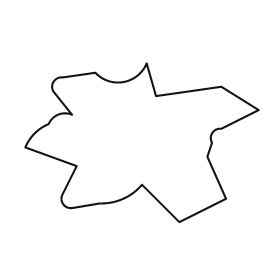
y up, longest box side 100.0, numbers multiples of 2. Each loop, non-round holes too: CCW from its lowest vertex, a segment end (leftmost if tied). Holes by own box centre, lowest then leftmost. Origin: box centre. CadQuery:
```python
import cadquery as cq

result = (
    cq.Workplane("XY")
    .moveTo(16.0, -34.0)
    .lineTo(36.0, -24.0)
    .lineTo(28.0, -6.0)
    .lineTo(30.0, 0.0)
    .threePointArc((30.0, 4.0), (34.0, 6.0))
    .lineTo(50.0, 14.0)
    .lineTo(34.0, 24.0)
    .lineTo(6.0, 20.0)
    .lineTo(2.0, 34.0)
    .threePointArc((-8.0, 26.0), (-20.0, 30.0))
    .lineTo(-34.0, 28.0)
    .threePointArc((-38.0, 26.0), (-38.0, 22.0))
    .lineTo(-30.0, 12.0)
    .threePointArc((-36.0, 12.0), (-40.0, 8.0))
    .threePointArc((-46.0, 4.0), (-50.0, -2.0))
    .lineTo(-28.0, -10.0)
    .lineTo(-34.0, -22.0)
    .threePointArc((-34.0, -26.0), (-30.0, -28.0))
    .lineTo(-18.0, -26.0)
    .threePointArc((-8.0, -24.0), (0.0, -18.0))
    .close()
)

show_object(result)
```